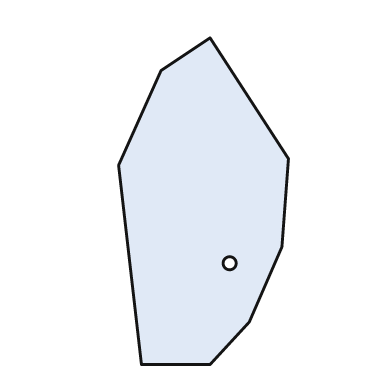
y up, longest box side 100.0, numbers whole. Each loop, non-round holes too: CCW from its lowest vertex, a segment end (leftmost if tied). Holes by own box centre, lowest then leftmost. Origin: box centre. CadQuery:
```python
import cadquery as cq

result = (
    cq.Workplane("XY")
    .moveTo(-19.0, -50.0)
    .lineTo(2.0, -50.0)
    .lineTo(14.0, -37.0)
    .lineTo(24.0, -14.0)
    .lineTo(26.0, 13.0)
    .lineTo(2.0, 50.0)
    .lineTo(-13.0, 40.0)
    .lineTo(-26.0, 11.0)
    .close()
    .moveTo(8.0, -19.0)
    .circle(2.0)
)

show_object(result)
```